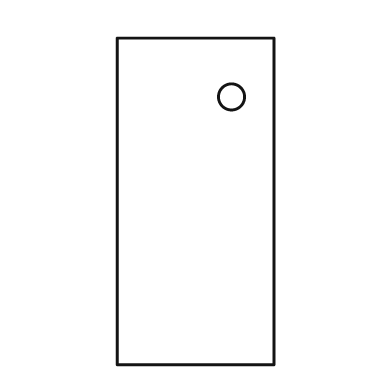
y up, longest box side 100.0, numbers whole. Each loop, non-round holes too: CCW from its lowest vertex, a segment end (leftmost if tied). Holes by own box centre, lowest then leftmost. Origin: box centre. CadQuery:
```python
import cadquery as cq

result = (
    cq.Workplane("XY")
    .moveTo(-24.0, -50.0)
    .lineTo(24.0, -50.0)
    .lineTo(24.0, 50.0)
    .lineTo(-24.0, 50.0)
    .close()
    .moveTo(11.0, 32.0)
    .circle(4.0)
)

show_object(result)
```